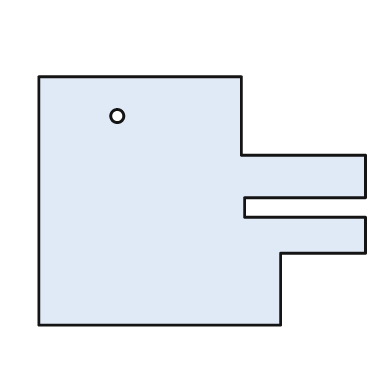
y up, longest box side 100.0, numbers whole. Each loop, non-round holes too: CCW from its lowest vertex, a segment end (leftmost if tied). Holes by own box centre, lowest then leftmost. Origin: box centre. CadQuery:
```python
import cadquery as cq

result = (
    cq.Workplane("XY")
    .moveTo(-50.0, -38.0)
    .lineTo(24.0, -38.0)
    .lineTo(24.0, -16.0)
    .lineTo(50.0, -16.0)
    .lineTo(50.0, -5.0)
    .lineTo(13.0, -5.0)
    .lineTo(13.0, 1.0)
    .lineTo(50.0, 1.0)
    .lineTo(50.0, 14.0)
    .lineTo(12.0, 14.0)
    .lineTo(12.0, 38.0)
    .lineTo(-50.0, 38.0)
    .close()
    .moveTo(-26.0, 26.0)
    .circle(2.0)
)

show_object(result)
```